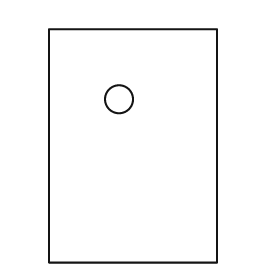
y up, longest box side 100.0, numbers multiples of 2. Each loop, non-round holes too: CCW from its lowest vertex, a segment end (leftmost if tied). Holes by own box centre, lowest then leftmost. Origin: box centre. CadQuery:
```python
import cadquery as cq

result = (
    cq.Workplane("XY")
    .moveTo(-36.0, -50.0)
    .lineTo(36.0, -50.0)
    .lineTo(36.0, 50.0)
    .lineTo(-36.0, 50.0)
    .close()
    .moveTo(-6.0, 20.0)
    .circle(6.0)
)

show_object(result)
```